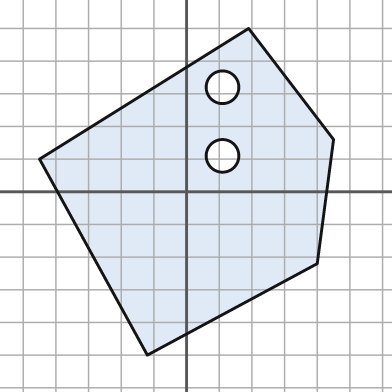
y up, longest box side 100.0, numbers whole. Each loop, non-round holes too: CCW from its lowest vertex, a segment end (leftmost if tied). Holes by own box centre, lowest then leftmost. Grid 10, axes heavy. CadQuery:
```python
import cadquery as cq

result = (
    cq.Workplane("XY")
    .moveTo(-12.0, -50.0)
    .lineTo(40.0, -22.0)
    .lineTo(45.0, 16.0)
    .lineTo(19.0, 50.0)
    .lineTo(-45.0, 10.0)
    .close()
    .moveTo(11.0, 11.0)
    .circle(5.0)
    .moveTo(11.0, 32.0)
    .circle(5.0)
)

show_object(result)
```